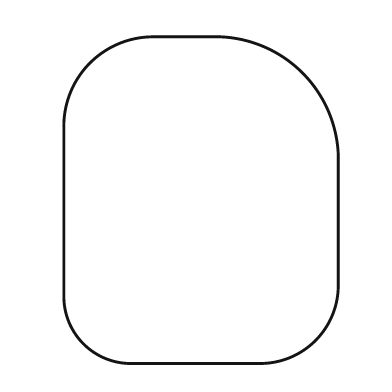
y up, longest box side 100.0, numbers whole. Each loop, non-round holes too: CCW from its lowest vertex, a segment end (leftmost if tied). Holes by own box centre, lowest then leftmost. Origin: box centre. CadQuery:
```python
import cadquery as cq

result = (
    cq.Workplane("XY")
    .moveTo(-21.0, -50.0)
    .lineTo(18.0, -50.0)
    .threePointArc((35.0, -43.0), (42.0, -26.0))
    .lineTo(42.0, 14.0)
    .threePointArc((31.0, 39.0), (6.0, 50.0))
    .lineTo(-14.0, 50.0)
    .threePointArc((-34.0, 42.0), (-42.0, 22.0))
    .lineTo(-42.0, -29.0)
    .threePointArc((-36.0, -44.0), (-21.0, -50.0))
    .close()
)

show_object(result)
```